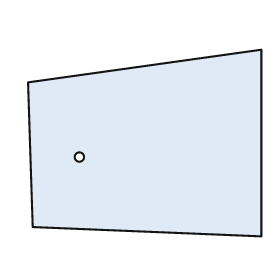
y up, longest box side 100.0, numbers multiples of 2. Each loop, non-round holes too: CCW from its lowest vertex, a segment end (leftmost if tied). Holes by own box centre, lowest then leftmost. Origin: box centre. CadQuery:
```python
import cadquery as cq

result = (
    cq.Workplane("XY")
    .moveTo(50.0, -40.0)
    .lineTo(50.0, 40.0)
    .lineTo(-50.0, 26.0)
    .lineTo(-48.0, -36.0)
    .close()
    .moveTo(-28.0, -6.0)
    .circle(2.0)
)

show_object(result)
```